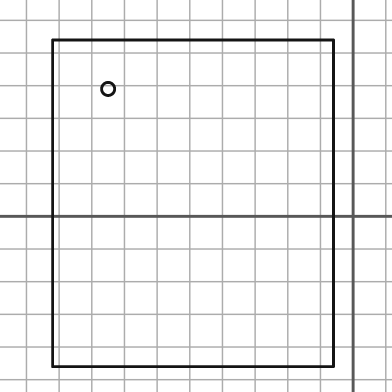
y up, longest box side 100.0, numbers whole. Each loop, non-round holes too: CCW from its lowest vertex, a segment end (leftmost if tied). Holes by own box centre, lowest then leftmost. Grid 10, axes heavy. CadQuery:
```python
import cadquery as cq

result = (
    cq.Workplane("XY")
    .moveTo(-92.0, -46.0)
    .lineTo(-6.0, -46.0)
    .lineTo(-6.0, 54.0)
    .lineTo(-92.0, 54.0)
    .close()
    .moveTo(-75.0, 39.0)
    .circle(2.0)
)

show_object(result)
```